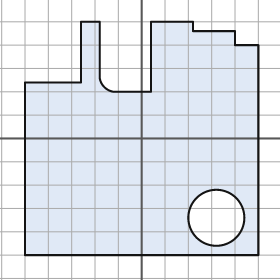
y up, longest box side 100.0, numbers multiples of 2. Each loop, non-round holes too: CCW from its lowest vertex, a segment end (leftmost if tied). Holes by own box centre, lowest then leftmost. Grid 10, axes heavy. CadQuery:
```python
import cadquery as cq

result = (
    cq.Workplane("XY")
    .moveTo(-50.0, -50.0)
    .lineTo(50.0, -50.0)
    .lineTo(50.0, 40.0)
    .lineTo(40.0, 40.0)
    .lineTo(40.0, 46.0)
    .lineTo(22.0, 46.0)
    .lineTo(22.0, 50.0)
    .lineTo(4.0, 50.0)
    .lineTo(4.0, 20.0)
    .lineTo(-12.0, 20.0)
    .threePointArc((-16.0, 22.0), (-18.0, 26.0))
    .lineTo(-18.0, 50.0)
    .lineTo(-26.0, 50.0)
    .lineTo(-26.0, 24.0)
    .lineTo(-50.0, 24.0)
    .close()
    .moveTo(32.0, -34.0)
    .circle(12.0)
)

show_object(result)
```